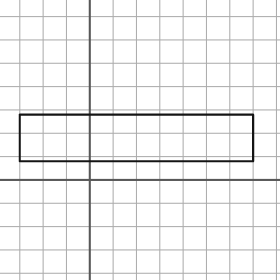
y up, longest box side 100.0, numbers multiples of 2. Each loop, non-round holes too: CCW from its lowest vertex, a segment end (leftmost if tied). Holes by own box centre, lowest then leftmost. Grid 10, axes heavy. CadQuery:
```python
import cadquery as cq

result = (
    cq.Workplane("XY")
    .moveTo(-30.0, 8.0)
    .lineTo(70.0, 8.0)
    .lineTo(70.0, 28.0)
    .lineTo(-30.0, 28.0)
    .close()
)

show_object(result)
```